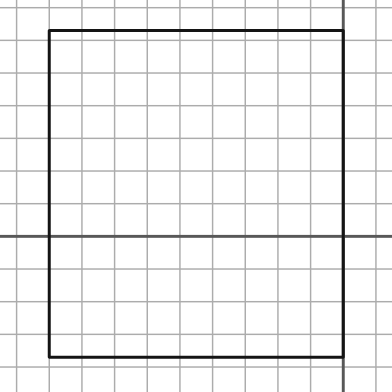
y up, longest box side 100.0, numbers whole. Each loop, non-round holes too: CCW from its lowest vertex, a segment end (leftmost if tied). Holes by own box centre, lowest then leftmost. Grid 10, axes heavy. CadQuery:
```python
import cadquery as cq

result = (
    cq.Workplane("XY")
    .moveTo(-90.0, -37.0)
    .lineTo(0.0, -37.0)
    .lineTo(0.0, 63.0)
    .lineTo(-90.0, 63.0)
    .close()
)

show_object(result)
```